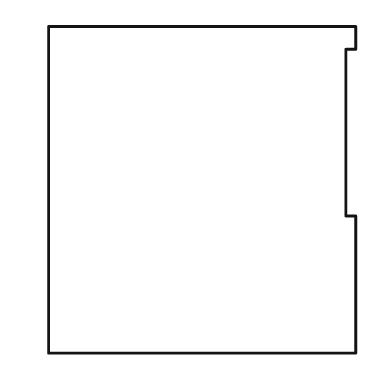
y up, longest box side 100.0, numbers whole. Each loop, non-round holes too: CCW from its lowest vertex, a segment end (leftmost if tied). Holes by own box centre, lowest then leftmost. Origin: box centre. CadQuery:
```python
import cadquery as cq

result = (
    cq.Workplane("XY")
    .moveTo(-47.0, -50.0)
    .lineTo(47.0, -50.0)
    .lineTo(47.0, -8.0)
    .lineTo(44.0, -8.0)
    .lineTo(44.0, 43.0)
    .lineTo(47.0, 43.0)
    .lineTo(47.0, 50.0)
    .lineTo(-47.0, 50.0)
    .close()
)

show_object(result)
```